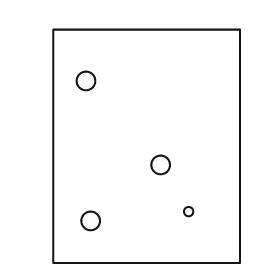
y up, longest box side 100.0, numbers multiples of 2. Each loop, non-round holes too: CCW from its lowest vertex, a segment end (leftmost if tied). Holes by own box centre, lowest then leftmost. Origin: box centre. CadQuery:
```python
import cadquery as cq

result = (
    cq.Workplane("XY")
    .moveTo(-40.0, -50.0)
    .lineTo(40.0, -50.0)
    .lineTo(40.0, 50.0)
    .lineTo(-40.0, 50.0)
    .close()
    .moveTo(-24.0, -32.0)
    .circle(4.0)
    .moveTo(18.0, -28.0)
    .circle(2.0)
    .moveTo(6.0, -8.0)
    .circle(4.0)
    .moveTo(-26.0, 28.0)
    .circle(4.0)
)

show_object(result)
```